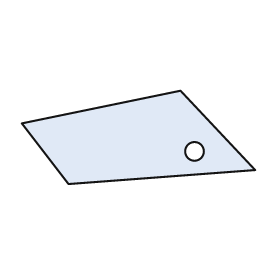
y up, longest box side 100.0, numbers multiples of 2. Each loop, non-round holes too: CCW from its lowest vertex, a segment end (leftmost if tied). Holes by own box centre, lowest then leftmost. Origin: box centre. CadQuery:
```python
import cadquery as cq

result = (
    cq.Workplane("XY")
    .moveTo(-30.0, -20.0)
    .lineTo(50.0, -14.0)
    .lineTo(18.0, 20.0)
    .lineTo(-50.0, 6.0)
    .close()
    .moveTo(24.0, -6.0)
    .circle(4.0)
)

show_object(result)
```